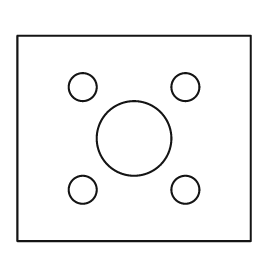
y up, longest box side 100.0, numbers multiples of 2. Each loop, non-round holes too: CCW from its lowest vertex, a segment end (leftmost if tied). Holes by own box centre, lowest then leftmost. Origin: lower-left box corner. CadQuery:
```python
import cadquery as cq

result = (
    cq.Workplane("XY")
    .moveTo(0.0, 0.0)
    .lineTo(100.0, 0.0)
    .lineTo(100.0, 88.0)
    .lineTo(0.0, 88.0)
    .close()
    .moveTo(28.0, 22.0)
    .circle(6.0)
    .moveTo(72.0, 22.0)
    .circle(6.0)
    .moveTo(50.0, 44.0)
    .circle(16.0)
    .moveTo(28.0, 66.0)
    .circle(6.0)
    .moveTo(72.0, 66.0)
    .circle(6.0)
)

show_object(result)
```